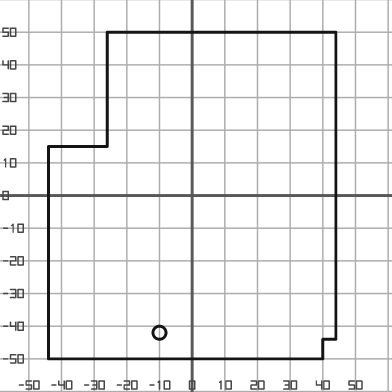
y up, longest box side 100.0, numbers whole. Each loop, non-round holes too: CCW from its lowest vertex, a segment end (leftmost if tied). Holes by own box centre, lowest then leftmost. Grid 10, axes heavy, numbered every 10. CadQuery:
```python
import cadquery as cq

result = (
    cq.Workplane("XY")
    .moveTo(-44.0, -50.0)
    .lineTo(40.0, -50.0)
    .lineTo(40.0, -44.0)
    .lineTo(44.0, -44.0)
    .lineTo(44.0, 50.0)
    .lineTo(-26.0, 50.0)
    .lineTo(-26.0, 15.0)
    .lineTo(-44.0, 15.0)
    .close()
    .moveTo(-10.0, -42.0)
    .circle(2.0)
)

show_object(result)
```